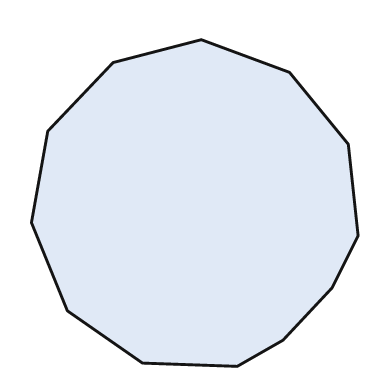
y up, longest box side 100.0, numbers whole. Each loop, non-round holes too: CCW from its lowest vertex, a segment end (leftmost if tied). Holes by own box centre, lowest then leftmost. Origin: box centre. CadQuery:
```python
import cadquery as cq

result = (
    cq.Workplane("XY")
    .moveTo(13.0, -50.0)
    .lineTo(27.0, -42.0)
    .lineTo(42.0, -26.0)
    .lineTo(50.0, -10.0)
    .lineTo(47.0, 18.0)
    .lineTo(29.0, 40.0)
    .lineTo(2.0, 50.0)
    .lineTo(-25.0, 43.0)
    .lineTo(-45.0, 22.0)
    .lineTo(-50.0, -6.0)
    .lineTo(-39.0, -33.0)
    .lineTo(-16.0, -49.0)
    .close()
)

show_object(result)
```